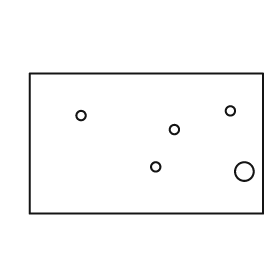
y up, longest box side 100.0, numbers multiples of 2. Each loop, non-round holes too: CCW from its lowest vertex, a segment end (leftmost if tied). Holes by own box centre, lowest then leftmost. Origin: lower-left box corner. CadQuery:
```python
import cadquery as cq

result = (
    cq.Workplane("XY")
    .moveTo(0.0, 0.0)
    .lineTo(100.0, 0.0)
    .lineTo(100.0, 60.0)
    .lineTo(0.0, 60.0)
    .close()
    .moveTo(92.0, 18.0)
    .circle(4.0)
    .moveTo(54.0, 20.0)
    .circle(2.0)
    .moveTo(62.0, 36.0)
    .circle(2.0)
    .moveTo(22.0, 42.0)
    .circle(2.0)
    .moveTo(86.0, 44.0)
    .circle(2.0)
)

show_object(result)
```